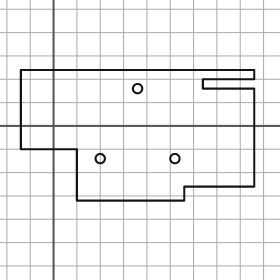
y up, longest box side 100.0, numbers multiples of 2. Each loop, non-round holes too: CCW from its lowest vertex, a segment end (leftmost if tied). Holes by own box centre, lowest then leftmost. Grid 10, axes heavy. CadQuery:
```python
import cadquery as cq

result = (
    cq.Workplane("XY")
    .moveTo(10.0, -32.0)
    .lineTo(56.0, -32.0)
    .lineTo(56.0, -26.0)
    .lineTo(86.0, -26.0)
    .lineTo(86.0, 16.0)
    .lineTo(64.0, 16.0)
    .lineTo(64.0, 20.0)
    .lineTo(86.0, 20.0)
    .lineTo(86.0, 24.0)
    .lineTo(-14.0, 24.0)
    .lineTo(-14.0, -10.0)
    .lineTo(10.0, -10.0)
    .close()
    .moveTo(20.0, -14.0)
    .circle(2.0)
    .moveTo(52.0, -14.0)
    .circle(2.0)
    .moveTo(36.0, 16.0)
    .circle(2.0)
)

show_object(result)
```